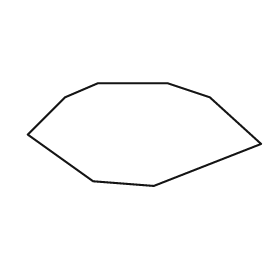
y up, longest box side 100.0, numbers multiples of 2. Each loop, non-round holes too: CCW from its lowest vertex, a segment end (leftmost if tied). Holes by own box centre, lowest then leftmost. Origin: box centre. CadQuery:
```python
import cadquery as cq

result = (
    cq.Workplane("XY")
    .moveTo(4.0, -22.0)
    .lineTo(50.0, -4.0)
    .lineTo(28.0, 16.0)
    .lineTo(10.0, 22.0)
    .lineTo(-20.0, 22.0)
    .lineTo(-34.0, 16.0)
    .lineTo(-50.0, 0.0)
    .lineTo(-22.0, -20.0)
    .close()
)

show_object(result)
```